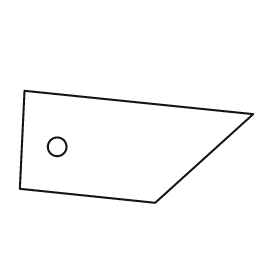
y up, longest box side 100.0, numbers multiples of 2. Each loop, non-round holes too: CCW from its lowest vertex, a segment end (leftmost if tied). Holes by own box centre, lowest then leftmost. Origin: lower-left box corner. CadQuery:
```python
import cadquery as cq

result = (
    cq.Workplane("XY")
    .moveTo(58.0, 0.0)
    .lineTo(100.0, 38.0)
    .lineTo(2.0, 48.0)
    .lineTo(0.0, 6.0)
    .close()
    .moveTo(16.0, 24.0)
    .circle(4.0)
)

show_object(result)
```